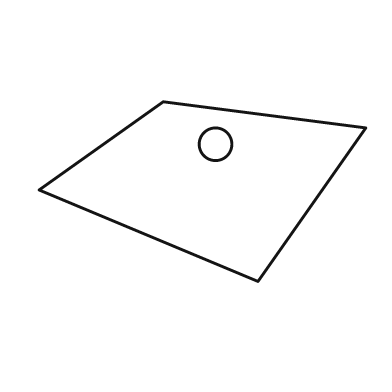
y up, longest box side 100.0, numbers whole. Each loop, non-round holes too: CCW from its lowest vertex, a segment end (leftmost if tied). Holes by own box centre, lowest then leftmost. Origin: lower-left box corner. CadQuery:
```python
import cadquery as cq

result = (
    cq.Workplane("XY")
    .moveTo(67.0, 0.0)
    .lineTo(100.0, 47.0)
    .lineTo(38.0, 55.0)
    .lineTo(0.0, 28.0)
    .close()
    .moveTo(54.0, 42.0)
    .circle(5.0)
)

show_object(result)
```